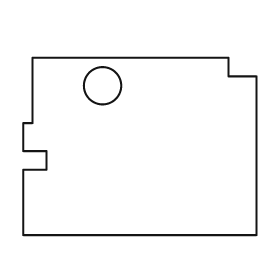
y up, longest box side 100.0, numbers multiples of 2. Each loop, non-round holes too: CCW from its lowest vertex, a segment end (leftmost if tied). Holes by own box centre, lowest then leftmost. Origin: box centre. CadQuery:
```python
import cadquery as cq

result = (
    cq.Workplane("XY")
    .moveTo(-50.0, -38.0)
    .lineTo(50.0, -38.0)
    .lineTo(50.0, 30.0)
    .lineTo(38.0, 30.0)
    .lineTo(38.0, 38.0)
    .lineTo(-46.0, 38.0)
    .lineTo(-46.0, 10.0)
    .lineTo(-50.0, 10.0)
    .lineTo(-50.0, -2.0)
    .lineTo(-40.0, -2.0)
    .lineTo(-40.0, -10.0)
    .lineTo(-50.0, -10.0)
    .close()
    .moveTo(-16.0, 26.0)
    .circle(8.0)
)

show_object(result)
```